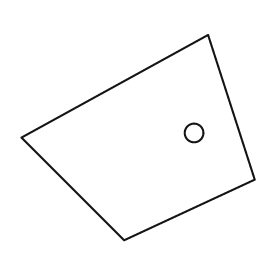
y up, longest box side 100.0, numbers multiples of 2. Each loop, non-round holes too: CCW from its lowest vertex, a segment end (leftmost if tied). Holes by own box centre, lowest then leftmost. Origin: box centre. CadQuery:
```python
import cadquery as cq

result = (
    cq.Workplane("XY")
    .moveTo(-6.0, -44.0)
    .lineTo(50.0, -18.0)
    .lineTo(30.0, 44.0)
    .lineTo(-50.0, 0.0)
    .close()
    .moveTo(24.0, 2.0)
    .circle(4.0)
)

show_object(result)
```